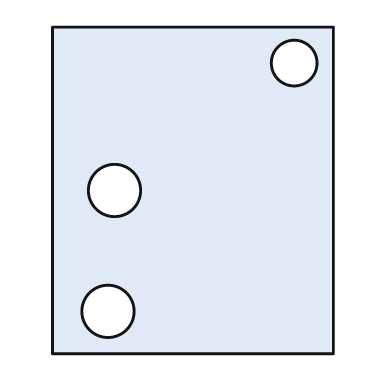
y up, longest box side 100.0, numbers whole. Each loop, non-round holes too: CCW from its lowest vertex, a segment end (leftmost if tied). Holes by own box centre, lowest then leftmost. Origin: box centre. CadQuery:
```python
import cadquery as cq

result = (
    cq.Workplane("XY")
    .moveTo(-43.0, -50.0)
    .lineTo(43.0, -50.0)
    .lineTo(43.0, 50.0)
    .lineTo(-43.0, 50.0)
    .close()
    .moveTo(-26.0, -37.0)
    .circle(8.0)
    .moveTo(-24.0, 0.0)
    .circle(8.0)
    .moveTo(31.0, 39.0)
    .circle(7.0)
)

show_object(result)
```